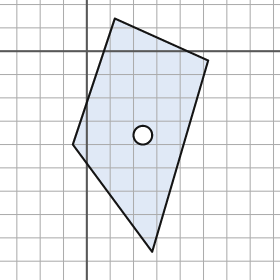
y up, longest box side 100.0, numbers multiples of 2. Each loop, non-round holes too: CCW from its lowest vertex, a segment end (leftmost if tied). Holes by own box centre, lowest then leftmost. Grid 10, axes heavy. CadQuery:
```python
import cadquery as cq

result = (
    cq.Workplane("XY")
    .moveTo(28.0, -86.0)
    .lineTo(52.0, -4.0)
    .lineTo(12.0, 14.0)
    .lineTo(-6.0, -40.0)
    .close()
    .moveTo(24.0, -36.0)
    .circle(4.0)
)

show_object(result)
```